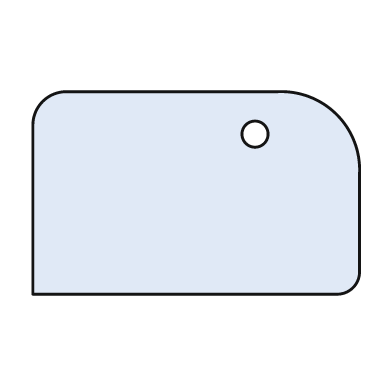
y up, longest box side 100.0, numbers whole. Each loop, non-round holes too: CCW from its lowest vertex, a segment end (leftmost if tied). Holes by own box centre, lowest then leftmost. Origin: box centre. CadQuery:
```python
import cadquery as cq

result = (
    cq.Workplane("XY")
    .moveTo(-50.0, -31.0)
    .lineTo(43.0, -31.0)
    .threePointArc((48.0, -29.0), (50.0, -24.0))
    .lineTo(50.0, 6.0)
    .threePointArc((43.0, 24.0), (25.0, 31.0))
    .lineTo(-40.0, 31.0)
    .threePointArc((-47.0, 28.0), (-50.0, 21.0))
    .close()
    .moveTo(18.0, 18.0)
    .circle(4.0)
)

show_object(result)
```